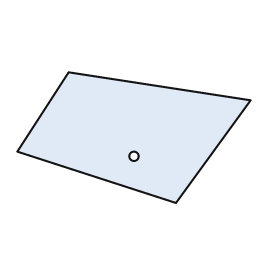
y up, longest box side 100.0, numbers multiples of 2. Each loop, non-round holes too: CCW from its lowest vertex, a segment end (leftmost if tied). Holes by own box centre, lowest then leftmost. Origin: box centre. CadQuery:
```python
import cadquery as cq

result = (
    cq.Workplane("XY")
    .moveTo(18.0, -28.0)
    .lineTo(50.0, 16.0)
    .lineTo(-28.0, 28.0)
    .lineTo(-50.0, -6.0)
    .close()
    .moveTo(0.0, -8.0)
    .circle(2.0)
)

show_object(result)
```